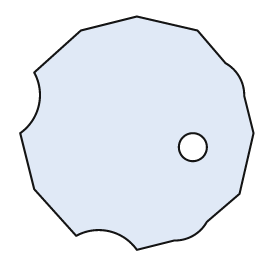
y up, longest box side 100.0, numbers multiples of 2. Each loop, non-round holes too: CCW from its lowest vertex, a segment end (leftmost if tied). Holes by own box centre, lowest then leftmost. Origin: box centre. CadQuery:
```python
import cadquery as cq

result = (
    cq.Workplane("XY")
    .moveTo(0.0, -50.0)
    .lineTo(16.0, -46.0)
    .threePointArc((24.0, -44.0), (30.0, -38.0))
    .lineTo(44.0, -26.0)
    .lineTo(50.0, 0.0)
    .lineTo(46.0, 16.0)
    .threePointArc((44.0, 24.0), (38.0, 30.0))
    .lineTo(26.0, 44.0)
    .lineTo(0.0, 50.0)
    .lineTo(-24.0, 44.0)
    .lineTo(-44.0, 26.0)
    .threePointArc((-42.0, 12.0), (-50.0, 0.0))
    .lineTo(-44.0, -24.0)
    .lineTo(-26.0, -44.0)
    .threePointArc((-12.0, -42.0), (0.0, -50.0))
    .close()
    .moveTo(24.0, -6.0)
    .circle(6.0)
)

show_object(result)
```